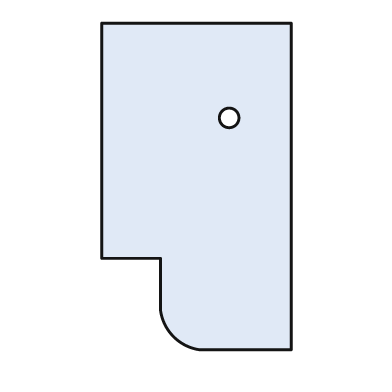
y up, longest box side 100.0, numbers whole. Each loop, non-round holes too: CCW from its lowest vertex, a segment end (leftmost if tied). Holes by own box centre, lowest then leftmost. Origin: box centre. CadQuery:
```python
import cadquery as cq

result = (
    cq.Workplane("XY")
    .moveTo(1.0, -50.0)
    .lineTo(29.0, -50.0)
    .lineTo(29.0, 50.0)
    .lineTo(-29.0, 50.0)
    .lineTo(-29.0, -22.0)
    .lineTo(-11.0, -22.0)
    .lineTo(-11.0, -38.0)
    .threePointArc((-7.0, -46.0), (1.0, -50.0))
    .close()
    .moveTo(10.0, 21.0)
    .circle(3.0)
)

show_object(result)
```